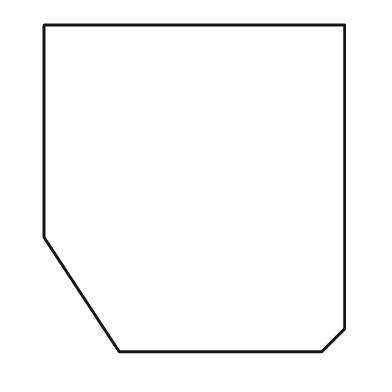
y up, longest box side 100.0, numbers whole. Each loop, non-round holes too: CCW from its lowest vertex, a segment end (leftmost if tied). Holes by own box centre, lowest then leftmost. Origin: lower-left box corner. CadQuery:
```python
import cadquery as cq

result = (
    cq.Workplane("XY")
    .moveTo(23.0, 0.0)
    .lineTo(85.0, 0.0)
    .lineTo(92.0, 7.0)
    .lineTo(92.0, 100.0)
    .lineTo(0.0, 100.0)
    .lineTo(0.0, 35.0)
    .close()
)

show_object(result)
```